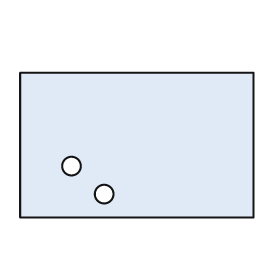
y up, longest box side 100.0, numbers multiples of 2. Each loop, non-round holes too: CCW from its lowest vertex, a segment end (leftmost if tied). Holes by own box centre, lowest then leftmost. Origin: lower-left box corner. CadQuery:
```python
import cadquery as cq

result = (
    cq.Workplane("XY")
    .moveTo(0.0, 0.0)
    .lineTo(100.0, 0.0)
    .lineTo(100.0, 62.0)
    .lineTo(0.0, 62.0)
    .close()
    .moveTo(36.0, 10.0)
    .circle(4.0)
    .moveTo(22.0, 22.0)
    .circle(4.0)
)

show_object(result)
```